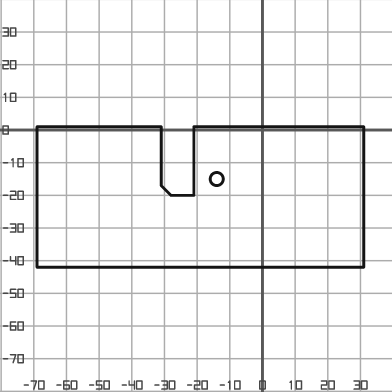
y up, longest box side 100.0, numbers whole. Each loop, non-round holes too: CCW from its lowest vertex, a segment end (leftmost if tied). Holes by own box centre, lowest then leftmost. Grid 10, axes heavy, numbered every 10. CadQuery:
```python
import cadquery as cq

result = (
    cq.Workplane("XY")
    .moveTo(-69.0, -42.0)
    .lineTo(31.0, -42.0)
    .lineTo(31.0, 1.0)
    .lineTo(-21.0, 1.0)
    .lineTo(-21.0, -20.0)
    .lineTo(-28.0, -20.0)
    .lineTo(-31.0, -17.0)
    .lineTo(-31.0, 1.0)
    .lineTo(-69.0, 1.0)
    .close()
    .moveTo(-14.0, -15.0)
    .circle(2.0)
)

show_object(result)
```